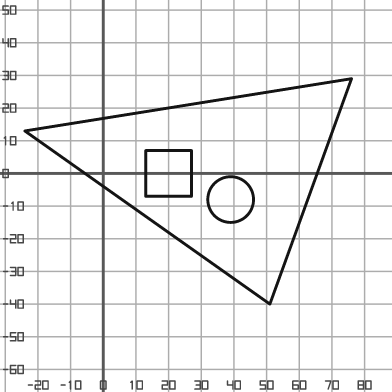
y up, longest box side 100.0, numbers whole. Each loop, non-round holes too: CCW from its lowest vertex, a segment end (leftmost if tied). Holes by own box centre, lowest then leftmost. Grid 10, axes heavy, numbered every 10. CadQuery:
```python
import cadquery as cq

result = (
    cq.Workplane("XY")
    .moveTo(51.0, -40.0)
    .lineTo(76.0, 29.0)
    .lineTo(-24.0, 13.0)
    .close()
    .moveTo(39.0, -8.0)
    .circle(7.0)
    .moveTo(13.0, -7.0)
    .lineTo(27.0, -7.0)
    .lineTo(27.0, 7.0)
    .lineTo(13.0, 7.0)
    .close()
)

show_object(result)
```